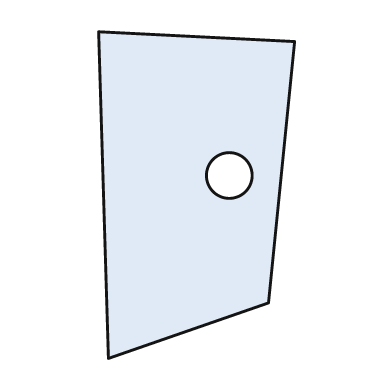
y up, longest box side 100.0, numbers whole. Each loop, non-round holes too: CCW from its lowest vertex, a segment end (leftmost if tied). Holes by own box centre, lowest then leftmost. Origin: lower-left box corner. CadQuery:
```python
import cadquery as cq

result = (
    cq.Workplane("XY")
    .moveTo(3.0, 0.0)
    .lineTo(52.0, 17.0)
    .lineTo(60.0, 97.0)
    .lineTo(0.0, 100.0)
    .close()
    .moveTo(40.0, 56.0)
    .circle(7.0)
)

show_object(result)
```